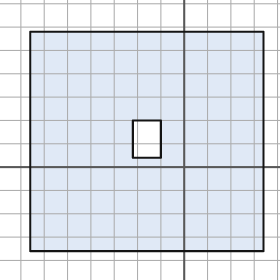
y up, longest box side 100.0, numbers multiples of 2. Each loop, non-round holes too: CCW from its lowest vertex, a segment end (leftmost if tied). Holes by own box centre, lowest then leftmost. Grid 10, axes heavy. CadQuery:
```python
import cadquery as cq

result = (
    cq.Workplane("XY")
    .moveTo(-66.0, -36.0)
    .lineTo(34.0, -36.0)
    .lineTo(34.0, 58.0)
    .lineTo(-66.0, 58.0)
    .close()
    .moveTo(-22.0, 4.0)
    .lineTo(-10.0, 4.0)
    .lineTo(-10.0, 20.0)
    .lineTo(-22.0, 20.0)
    .close()
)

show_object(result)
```